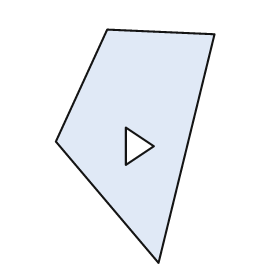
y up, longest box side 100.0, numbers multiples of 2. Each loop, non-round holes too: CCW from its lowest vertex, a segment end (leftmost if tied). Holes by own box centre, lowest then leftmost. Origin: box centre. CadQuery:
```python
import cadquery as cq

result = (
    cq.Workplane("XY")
    .moveTo(10.0, -50.0)
    .lineTo(34.0, 48.0)
    .lineTo(-12.0, 50.0)
    .lineTo(-34.0, 2.0)
    .close()
    .moveTo(-4.0, -8.0)
    .lineTo(8.0, 0.0)
    .lineTo(-4.0, 8.0)
    .close()
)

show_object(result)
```